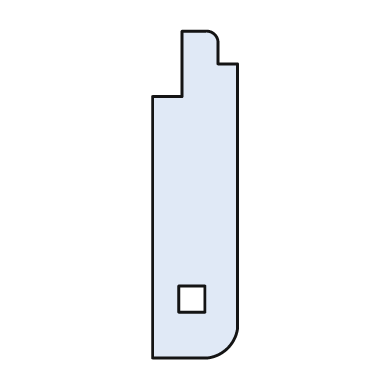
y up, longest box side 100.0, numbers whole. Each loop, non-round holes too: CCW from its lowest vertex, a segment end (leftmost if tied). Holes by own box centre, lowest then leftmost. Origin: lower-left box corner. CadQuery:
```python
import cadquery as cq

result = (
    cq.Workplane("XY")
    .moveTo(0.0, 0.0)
    .lineTo(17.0, 0.0)
    .threePointArc((23.0, 3.0), (26.0, 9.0))
    .lineTo(26.0, 90.0)
    .lineTo(20.0, 90.0)
    .lineTo(20.0, 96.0)
    .threePointArc((19.0, 99.0), (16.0, 100.0))
    .lineTo(9.0, 100.0)
    .lineTo(9.0, 80.0)
    .lineTo(0.0, 80.0)
    .close()
    .moveTo(8.0, 14.0)
    .lineTo(16.0, 14.0)
    .lineTo(16.0, 22.0)
    .lineTo(8.0, 22.0)
    .close()
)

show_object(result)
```